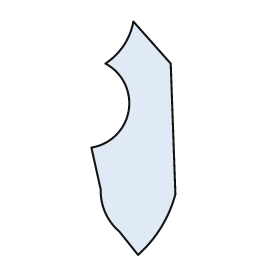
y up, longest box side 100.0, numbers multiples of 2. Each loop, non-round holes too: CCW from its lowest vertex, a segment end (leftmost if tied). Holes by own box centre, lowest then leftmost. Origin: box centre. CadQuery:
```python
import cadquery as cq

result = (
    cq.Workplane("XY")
    .moveTo(2.0, -50.0)
    .threePointArc((12.0, -38.0), (18.0, -24.0))
    .lineTo(16.0, 32.0)
    .lineTo(0.0, 50.0)
    .threePointArc((-4.0, 40.0), (-12.0, 32.0))
    .threePointArc((-2.0, 12.0), (-18.0, -4.0))
    .lineTo(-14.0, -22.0)
    .threePointArc((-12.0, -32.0), (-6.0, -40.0))
    .close()
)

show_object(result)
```